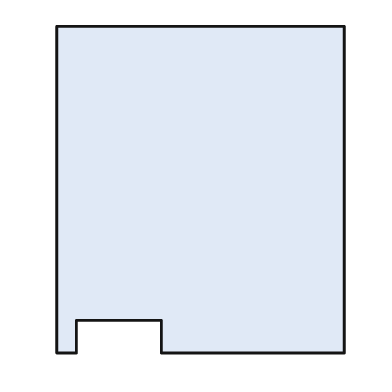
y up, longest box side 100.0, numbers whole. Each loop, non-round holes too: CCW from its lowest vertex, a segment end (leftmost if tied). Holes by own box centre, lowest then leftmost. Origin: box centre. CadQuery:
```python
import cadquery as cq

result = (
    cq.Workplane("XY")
    .moveTo(-44.0, -50.0)
    .lineTo(-38.0, -50.0)
    .lineTo(-38.0, -40.0)
    .lineTo(-12.0, -40.0)
    .lineTo(-12.0, -50.0)
    .lineTo(44.0, -50.0)
    .lineTo(44.0, 50.0)
    .lineTo(-44.0, 50.0)
    .close()
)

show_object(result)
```